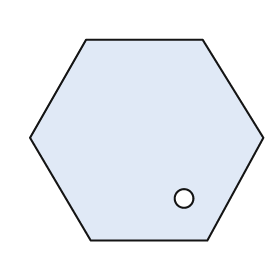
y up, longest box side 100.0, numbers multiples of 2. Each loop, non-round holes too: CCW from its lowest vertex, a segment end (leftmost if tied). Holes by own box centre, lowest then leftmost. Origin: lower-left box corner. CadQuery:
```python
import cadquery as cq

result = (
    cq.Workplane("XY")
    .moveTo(26.0, 0.0)
    .lineTo(76.0, 0.0)
    .lineTo(100.0, 44.0)
    .lineTo(74.0, 86.0)
    .lineTo(24.0, 86.0)
    .lineTo(0.0, 44.0)
    .close()
    .moveTo(66.0, 18.0)
    .circle(4.0)
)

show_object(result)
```